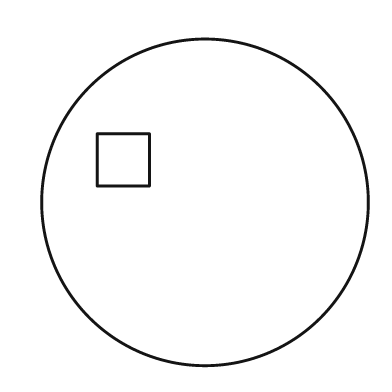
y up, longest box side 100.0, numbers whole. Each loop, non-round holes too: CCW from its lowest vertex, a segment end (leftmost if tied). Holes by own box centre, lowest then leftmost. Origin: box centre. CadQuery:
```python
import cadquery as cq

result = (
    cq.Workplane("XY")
    .moveTo(0.0, 0.0)
    .circle(50.0)
    .moveTo(-33.0, 5.0)
    .lineTo(-17.0, 5.0)
    .lineTo(-17.0, 21.0)
    .lineTo(-33.0, 21.0)
    .close()
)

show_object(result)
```